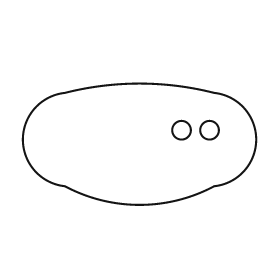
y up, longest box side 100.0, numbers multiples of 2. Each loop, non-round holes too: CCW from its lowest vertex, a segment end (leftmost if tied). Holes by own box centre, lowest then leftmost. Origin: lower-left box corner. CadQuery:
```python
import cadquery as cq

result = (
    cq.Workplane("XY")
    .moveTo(18.0, 8.0)
    .threePointArc((50.0, 0.0), (82.0, 8.0))
    .threePointArc((100.0, 28.0), (82.0, 48.0))
    .threePointArc((50.0, 52.0), (18.0, 48.0))
    .threePointArc((0.0, 28.0), (18.0, 8.0))
    .close()
    .moveTo(68.0, 32.0)
    .circle(4.0)
    .moveTo(80.0, 32.0)
    .circle(4.0)
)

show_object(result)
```